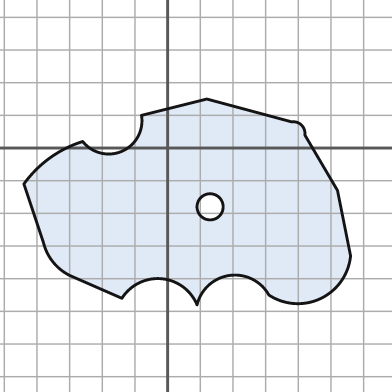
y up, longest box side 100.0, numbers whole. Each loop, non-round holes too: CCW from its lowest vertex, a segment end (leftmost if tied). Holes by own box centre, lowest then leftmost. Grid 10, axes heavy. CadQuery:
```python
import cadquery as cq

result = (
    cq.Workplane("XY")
    .moveTo(9.0, -48.0)
    .threePointArc((19.0, -39.0), (31.0, -45.0))
    .threePointArc((47.0, -46.0), (56.0, -33.0))
    .lineTo(52.0, -13.0)
    .lineTo(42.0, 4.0)
    .threePointArc((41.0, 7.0), (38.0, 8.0))
    .lineTo(12.0, 15.0)
    .lineTo(-8.0, 10.0)
    .threePointArc((-14.0, -1.0), (-26.0, 2.0))
    .threePointArc((-36.0, -3.0), (-44.0, -11.0))
    .lineTo(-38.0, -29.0)
    .threePointArc((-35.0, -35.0), (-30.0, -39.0))
    .lineTo(-14.0, -46.0)
    .threePointArc((-2.0, -40.0), (9.0, -48.0))
    .close()
    .moveTo(13.0, -18.0)
    .circle(4.0)
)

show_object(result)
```